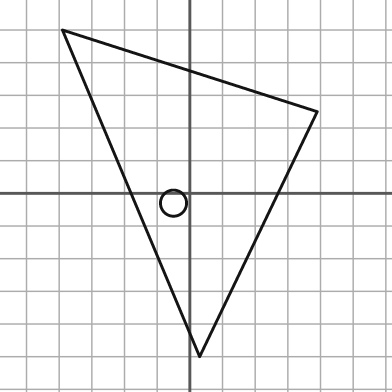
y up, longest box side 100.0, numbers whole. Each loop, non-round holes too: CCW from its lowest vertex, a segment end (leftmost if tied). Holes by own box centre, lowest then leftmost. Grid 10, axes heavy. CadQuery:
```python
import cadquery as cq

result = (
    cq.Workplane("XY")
    .moveTo(3.0, -50.0)
    .lineTo(39.0, 25.0)
    .lineTo(-39.0, 50.0)
    .close()
    .moveTo(-5.0, -3.0)
    .circle(4.0)
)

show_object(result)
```